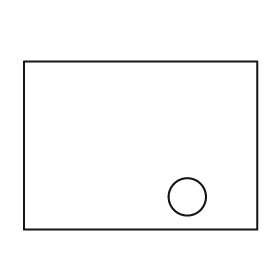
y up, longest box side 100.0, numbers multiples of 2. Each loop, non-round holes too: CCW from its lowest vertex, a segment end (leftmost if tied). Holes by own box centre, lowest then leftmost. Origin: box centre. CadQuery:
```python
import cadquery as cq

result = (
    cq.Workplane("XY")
    .moveTo(-50.0, -36.0)
    .lineTo(50.0, -36.0)
    .lineTo(50.0, 36.0)
    .lineTo(-50.0, 36.0)
    .close()
    .moveTo(20.0, -22.0)
    .circle(8.0)
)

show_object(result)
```